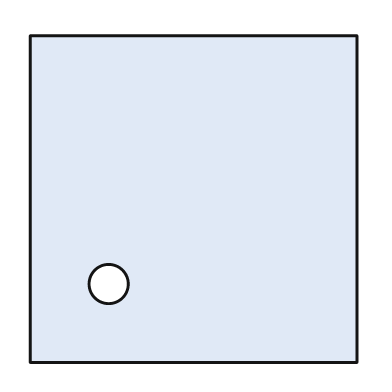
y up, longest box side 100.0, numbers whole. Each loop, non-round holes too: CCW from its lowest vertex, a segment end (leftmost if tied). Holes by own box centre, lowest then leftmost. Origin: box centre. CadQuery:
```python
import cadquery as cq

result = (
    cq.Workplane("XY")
    .moveTo(-50.0, -50.0)
    .lineTo(50.0, -50.0)
    .lineTo(50.0, 50.0)
    .lineTo(-50.0, 50.0)
    .close()
    .moveTo(-26.0, -26.0)
    .circle(6.0)
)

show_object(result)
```